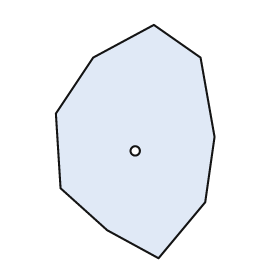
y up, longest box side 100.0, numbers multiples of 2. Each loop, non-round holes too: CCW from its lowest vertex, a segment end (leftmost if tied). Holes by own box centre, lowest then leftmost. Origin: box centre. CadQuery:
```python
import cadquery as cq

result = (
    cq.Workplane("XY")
    .moveTo(10.0, -50.0)
    .lineTo(30.0, -26.0)
    .lineTo(34.0, 2.0)
    .lineTo(28.0, 36.0)
    .lineTo(8.0, 50.0)
    .lineTo(-18.0, 36.0)
    .lineTo(-34.0, 12.0)
    .lineTo(-32.0, -20.0)
    .lineTo(-12.0, -38.0)
    .close()
    .moveTo(0.0, -4.0)
    .circle(2.0)
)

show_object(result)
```